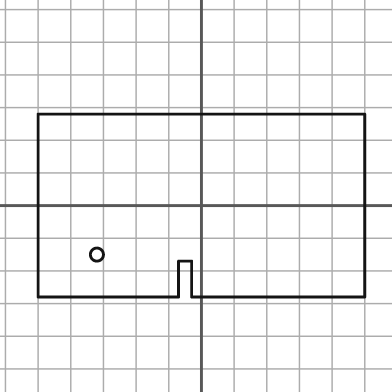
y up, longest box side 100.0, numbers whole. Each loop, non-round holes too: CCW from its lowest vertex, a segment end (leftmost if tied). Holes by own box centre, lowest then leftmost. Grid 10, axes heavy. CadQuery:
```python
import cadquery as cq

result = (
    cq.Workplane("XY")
    .moveTo(-50.0, -28.0)
    .lineTo(-7.0, -28.0)
    .lineTo(-7.0, -17.0)
    .lineTo(-3.0, -17.0)
    .lineTo(-3.0, -28.0)
    .lineTo(50.0, -28.0)
    .lineTo(50.0, 28.0)
    .lineTo(-50.0, 28.0)
    .close()
    .moveTo(-32.0, -15.0)
    .circle(2.0)
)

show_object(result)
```